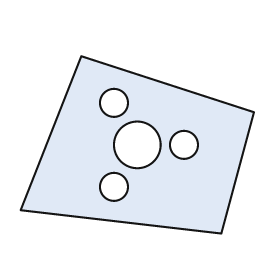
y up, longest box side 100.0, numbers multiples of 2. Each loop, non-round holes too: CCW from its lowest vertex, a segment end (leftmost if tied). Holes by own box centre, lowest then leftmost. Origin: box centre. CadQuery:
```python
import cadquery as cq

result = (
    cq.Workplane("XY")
    .moveTo(36.0, -38.0)
    .lineTo(50.0, 14.0)
    .lineTo(-24.0, 38.0)
    .lineTo(-50.0, -28.0)
    .close()
    .moveTo(-10.0, -18.0)
    .circle(6.0)
    .moveTo(0.0, 0.0)
    .circle(10.0)
    .moveTo(20.0, 0.0)
    .circle(6.0)
    .moveTo(-10.0, 18.0)
    .circle(6.0)
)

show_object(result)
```